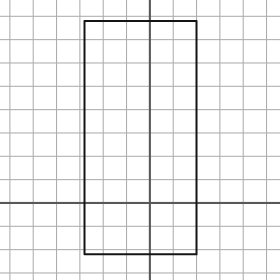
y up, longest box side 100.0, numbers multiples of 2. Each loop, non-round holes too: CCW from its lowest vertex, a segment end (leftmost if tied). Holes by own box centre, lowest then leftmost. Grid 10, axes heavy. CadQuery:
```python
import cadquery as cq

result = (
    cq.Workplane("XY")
    .moveTo(-28.0, -22.0)
    .lineTo(20.0, -22.0)
    .lineTo(20.0, 78.0)
    .lineTo(-28.0, 78.0)
    .close()
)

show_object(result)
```